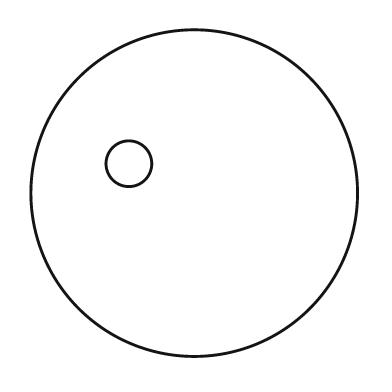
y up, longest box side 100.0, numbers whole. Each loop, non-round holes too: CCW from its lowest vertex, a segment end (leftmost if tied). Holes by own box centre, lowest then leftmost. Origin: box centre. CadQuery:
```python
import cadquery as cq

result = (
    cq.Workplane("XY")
    .moveTo(0.0, 0.0)
    .circle(50.0)
    .moveTo(-20.0, 9.0)
    .circle(7.0)
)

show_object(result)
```